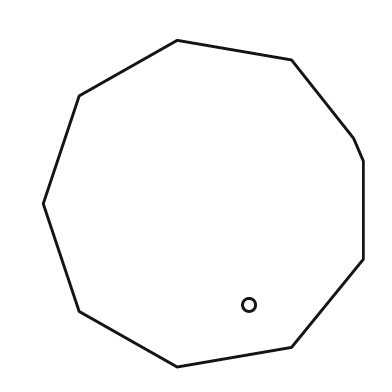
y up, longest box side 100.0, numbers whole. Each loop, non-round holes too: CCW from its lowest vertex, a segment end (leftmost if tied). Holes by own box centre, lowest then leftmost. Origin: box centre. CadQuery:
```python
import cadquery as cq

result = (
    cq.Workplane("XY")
    .moveTo(-8.0, -50.0)
    .lineTo(27.0, -44.0)
    .lineTo(49.0, -17.0)
    .lineTo(49.0, 13.0)
    .lineTo(46.0, 20.0)
    .lineTo(27.0, 44.0)
    .lineTo(-8.0, 50.0)
    .lineTo(-38.0, 33.0)
    .lineTo(-49.0, 0.0)
    .lineTo(-38.0, -33.0)
    .close()
    .moveTo(14.0, -31.0)
    .circle(2.0)
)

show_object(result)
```